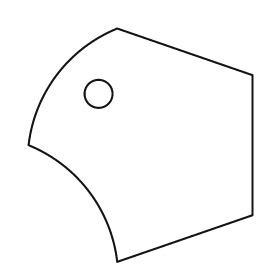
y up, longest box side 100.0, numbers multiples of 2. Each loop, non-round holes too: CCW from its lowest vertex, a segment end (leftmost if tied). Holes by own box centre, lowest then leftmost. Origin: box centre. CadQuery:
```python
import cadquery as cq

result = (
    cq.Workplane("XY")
    .moveTo(-10.0, -50.0)
    .lineTo(48.0, -30.0)
    .lineTo(48.0, 30.0)
    .lineTo(-10.0, 50.0)
    .threePointArc((-36.0, 30.0), (-48.0, 0.0))
    .threePointArc((-22.0, -20.0), (-10.0, -50.0))
    .close()
    .moveTo(-18.0, 22.0)
    .circle(6.0)
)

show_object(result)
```